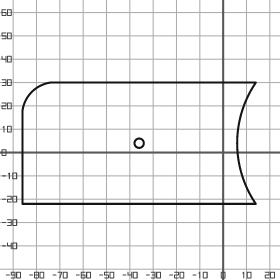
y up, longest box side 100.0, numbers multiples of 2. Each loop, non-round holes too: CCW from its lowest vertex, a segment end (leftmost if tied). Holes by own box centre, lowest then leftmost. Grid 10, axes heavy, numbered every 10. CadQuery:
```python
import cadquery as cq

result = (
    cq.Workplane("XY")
    .moveTo(-86.0, -22.0)
    .lineTo(14.0, -22.0)
    .threePointArc((6.0, 4.0), (14.0, 30.0))
    .lineTo(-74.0, 30.0)
    .threePointArc((-82.0, 26.0), (-86.0, 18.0))
    .close()
    .moveTo(-36.0, 4.0)
    .circle(2.0)
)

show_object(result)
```